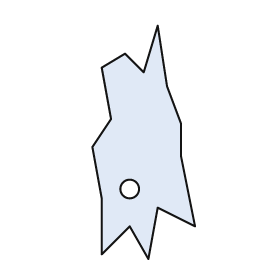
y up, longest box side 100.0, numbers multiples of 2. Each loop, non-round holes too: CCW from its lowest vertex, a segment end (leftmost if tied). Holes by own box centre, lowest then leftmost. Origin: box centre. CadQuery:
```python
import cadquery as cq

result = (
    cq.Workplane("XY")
    .moveTo(2.0, -50.0)
    .lineTo(6.0, -28.0)
    .lineTo(22.0, -36.0)
    .lineTo(16.0, -6.0)
    .lineTo(16.0, 8.0)
    .lineTo(10.0, 24.0)
    .lineTo(6.0, 50.0)
    .lineTo(0.0, 30.0)
    .lineTo(-8.0, 38.0)
    .lineTo(-18.0, 32.0)
    .lineTo(-14.0, 10.0)
    .lineTo(-22.0, -2.0)
    .lineTo(-18.0, -24.0)
    .lineTo(-18.0, -48.0)
    .lineTo(-6.0, -36.0)
    .close()
    .moveTo(-6.0, -20.0)
    .circle(4.0)
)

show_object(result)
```